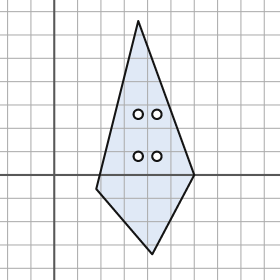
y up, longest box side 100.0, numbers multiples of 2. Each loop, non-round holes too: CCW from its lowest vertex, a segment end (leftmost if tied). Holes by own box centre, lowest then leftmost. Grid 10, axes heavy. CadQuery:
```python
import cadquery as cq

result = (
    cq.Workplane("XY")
    .moveTo(42.0, -34.0)
    .lineTo(60.0, 0.0)
    .lineTo(36.0, 66.0)
    .lineTo(18.0, -6.0)
    .close()
    .moveTo(36.0, 8.0)
    .circle(2.0)
    .moveTo(44.0, 8.0)
    .circle(2.0)
    .moveTo(36.0, 26.0)
    .circle(2.0)
    .moveTo(44.0, 26.0)
    .circle(2.0)
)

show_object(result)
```